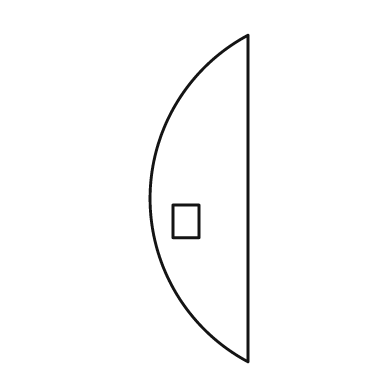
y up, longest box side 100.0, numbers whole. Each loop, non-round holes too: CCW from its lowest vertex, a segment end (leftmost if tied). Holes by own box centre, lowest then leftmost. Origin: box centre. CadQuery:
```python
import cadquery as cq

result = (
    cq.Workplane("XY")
    .moveTo(15.0, -50.0)
    .lineTo(15.0, 50.0)
    .threePointArc((-15.0, 0.0), (15.0, -50.0))
    .close()
    .moveTo(-8.0, -12.0)
    .lineTo(0.0, -12.0)
    .lineTo(0.0, -2.0)
    .lineTo(-8.0, -2.0)
    .close()
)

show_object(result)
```